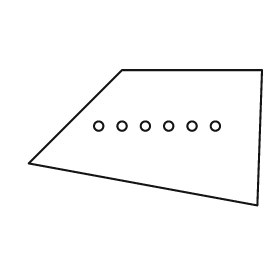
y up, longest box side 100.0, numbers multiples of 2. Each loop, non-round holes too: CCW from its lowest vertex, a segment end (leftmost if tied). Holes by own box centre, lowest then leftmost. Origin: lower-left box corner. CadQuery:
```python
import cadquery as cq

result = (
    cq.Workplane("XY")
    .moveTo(98.0, 0.0)
    .lineTo(100.0, 58.0)
    .lineTo(40.0, 58.0)
    .lineTo(0.0, 18.0)
    .close()
    .moveTo(30.0, 34.0)
    .circle(2.0)
    .moveTo(40.0, 34.0)
    .circle(2.0)
    .moveTo(50.0, 34.0)
    .circle(2.0)
    .moveTo(60.0, 34.0)
    .circle(2.0)
    .moveTo(70.0, 34.0)
    .circle(2.0)
    .moveTo(80.0, 34.0)
    .circle(2.0)
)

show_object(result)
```